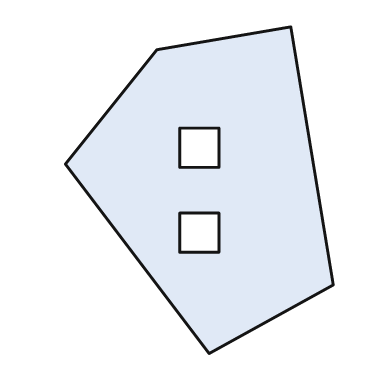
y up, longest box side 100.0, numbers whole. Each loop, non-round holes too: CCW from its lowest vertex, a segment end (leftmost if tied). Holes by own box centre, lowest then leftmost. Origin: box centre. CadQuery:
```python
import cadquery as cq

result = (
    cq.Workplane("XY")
    .moveTo(3.0, -50.0)
    .lineTo(41.0, -29.0)
    .lineTo(28.0, 50.0)
    .lineTo(-13.0, 43.0)
    .lineTo(-41.0, 8.0)
    .close()
    .moveTo(-6.0, -19.0)
    .lineTo(6.0, -19.0)
    .lineTo(6.0, -7.0)
    .lineTo(-6.0, -7.0)
    .close()
    .moveTo(-6.0, 7.0)
    .lineTo(6.0, 7.0)
    .lineTo(6.0, 19.0)
    .lineTo(-6.0, 19.0)
    .close()
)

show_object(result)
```